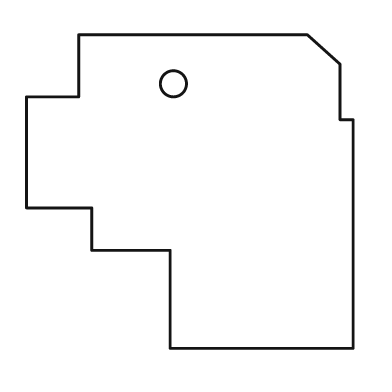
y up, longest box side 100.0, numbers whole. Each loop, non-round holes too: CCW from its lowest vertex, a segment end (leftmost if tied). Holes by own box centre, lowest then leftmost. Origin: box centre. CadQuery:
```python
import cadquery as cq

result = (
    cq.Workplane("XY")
    .moveTo(-6.0, -48.0)
    .lineTo(50.0, -48.0)
    .lineTo(50.0, 22.0)
    .lineTo(46.0, 22.0)
    .lineTo(46.0, 39.0)
    .lineTo(36.0, 48.0)
    .lineTo(-34.0, 48.0)
    .lineTo(-34.0, 29.0)
    .lineTo(-50.0, 29.0)
    .lineTo(-50.0, -5.0)
    .lineTo(-30.0, -5.0)
    .lineTo(-30.0, -18.0)
    .lineTo(-6.0, -18.0)
    .close()
    .moveTo(-5.0, 33.0)
    .circle(4.0)
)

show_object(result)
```